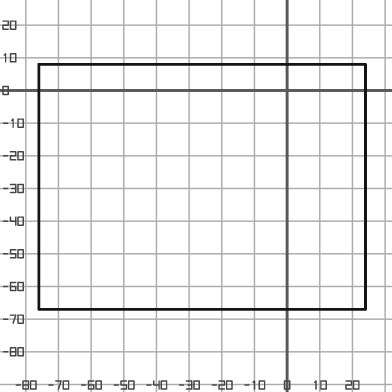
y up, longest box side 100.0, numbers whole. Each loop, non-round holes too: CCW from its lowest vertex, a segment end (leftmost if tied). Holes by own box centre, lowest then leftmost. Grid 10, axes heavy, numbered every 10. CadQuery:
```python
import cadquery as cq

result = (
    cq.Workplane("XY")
    .moveTo(-76.0, -67.0)
    .lineTo(24.0, -67.0)
    .lineTo(24.0, 8.0)
    .lineTo(-76.0, 8.0)
    .close()
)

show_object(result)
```